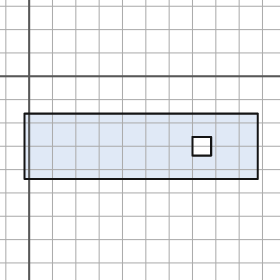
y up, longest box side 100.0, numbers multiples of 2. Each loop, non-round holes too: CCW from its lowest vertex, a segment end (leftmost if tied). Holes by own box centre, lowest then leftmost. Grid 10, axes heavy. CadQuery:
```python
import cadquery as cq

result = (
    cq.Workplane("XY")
    .moveTo(-2.0, -44.0)
    .lineTo(98.0, -44.0)
    .lineTo(98.0, -16.0)
    .lineTo(-2.0, -16.0)
    .close()
    .moveTo(70.0, -34.0)
    .lineTo(78.0, -34.0)
    .lineTo(78.0, -26.0)
    .lineTo(70.0, -26.0)
    .close()
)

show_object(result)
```